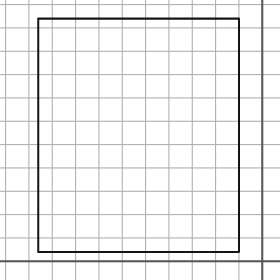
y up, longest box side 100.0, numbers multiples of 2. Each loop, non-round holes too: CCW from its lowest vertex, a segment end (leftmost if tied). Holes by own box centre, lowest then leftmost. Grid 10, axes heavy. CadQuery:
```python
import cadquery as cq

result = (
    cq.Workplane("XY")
    .moveTo(-96.0, 4.0)
    .lineTo(-10.0, 4.0)
    .lineTo(-10.0, 104.0)
    .lineTo(-96.0, 104.0)
    .close()
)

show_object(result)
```